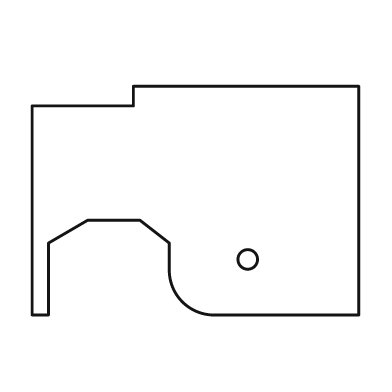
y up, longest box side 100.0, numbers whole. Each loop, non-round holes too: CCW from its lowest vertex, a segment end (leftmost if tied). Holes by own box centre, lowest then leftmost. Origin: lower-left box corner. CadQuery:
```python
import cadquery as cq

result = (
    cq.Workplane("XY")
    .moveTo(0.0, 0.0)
    .lineTo(5.0, 0.0)
    .lineTo(5.0, 22.0)
    .lineTo(17.0, 29.0)
    .lineTo(33.0, 29.0)
    .lineTo(42.0, 22.0)
    .lineTo(42.0, 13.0)
    .threePointArc((46.0, 4.0), (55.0, 0.0))
    .lineTo(100.0, 0.0)
    .lineTo(100.0, 70.0)
    .lineTo(31.0, 70.0)
    .lineTo(31.0, 64.0)
    .lineTo(0.0, 64.0)
    .close()
    .moveTo(66.0, 17.0)
    .circle(3.0)
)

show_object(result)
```